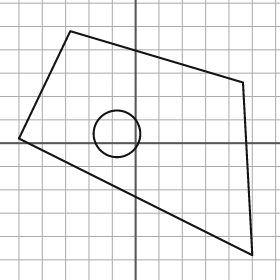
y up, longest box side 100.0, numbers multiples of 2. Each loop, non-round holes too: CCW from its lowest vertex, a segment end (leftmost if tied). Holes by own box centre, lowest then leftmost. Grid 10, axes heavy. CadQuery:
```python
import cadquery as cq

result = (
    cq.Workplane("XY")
    .moveTo(50.0, -48.0)
    .lineTo(46.0, 26.0)
    .lineTo(-28.0, 48.0)
    .lineTo(-50.0, 2.0)
    .close()
    .moveTo(-8.0, 4.0)
    .circle(10.0)
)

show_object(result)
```